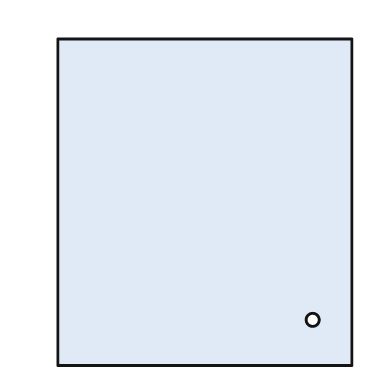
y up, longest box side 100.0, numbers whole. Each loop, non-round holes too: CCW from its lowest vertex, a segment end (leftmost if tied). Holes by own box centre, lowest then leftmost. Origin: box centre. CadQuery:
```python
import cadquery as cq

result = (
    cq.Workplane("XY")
    .moveTo(-45.0, -50.0)
    .lineTo(45.0, -50.0)
    .lineTo(45.0, 50.0)
    .lineTo(-45.0, 50.0)
    .close()
    .moveTo(33.0, -36.0)
    .circle(2.0)
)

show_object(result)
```